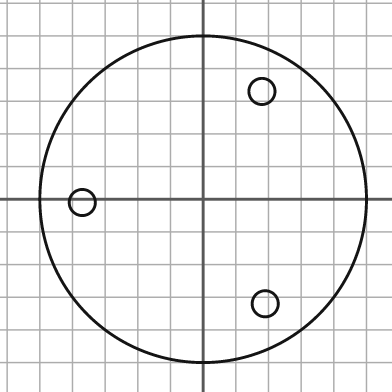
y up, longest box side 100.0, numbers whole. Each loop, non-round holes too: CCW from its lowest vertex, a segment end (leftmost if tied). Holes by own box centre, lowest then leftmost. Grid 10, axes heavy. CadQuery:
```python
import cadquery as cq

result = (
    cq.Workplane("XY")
    .moveTo(0.0, 0.0)
    .circle(50.0)
    .moveTo(19.0, -32.0)
    .circle(4.0)
    .moveTo(-37.0, -1.0)
    .circle(4.0)
    .moveTo(18.0, 33.0)
    .circle(4.0)
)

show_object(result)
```